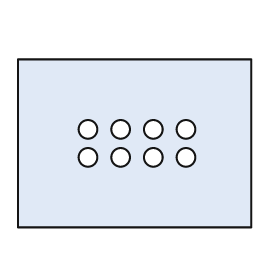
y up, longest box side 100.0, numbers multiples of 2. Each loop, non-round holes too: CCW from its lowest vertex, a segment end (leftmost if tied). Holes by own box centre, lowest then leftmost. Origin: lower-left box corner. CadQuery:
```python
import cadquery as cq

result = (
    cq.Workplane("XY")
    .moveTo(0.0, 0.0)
    .lineTo(100.0, 0.0)
    .lineTo(100.0, 72.0)
    .lineTo(0.0, 72.0)
    .close()
    .moveTo(30.0, 30.0)
    .circle(4.0)
    .moveTo(44.0, 30.0)
    .circle(4.0)
    .moveTo(58.0, 30.0)
    .circle(4.0)
    .moveTo(72.0, 30.0)
    .circle(4.0)
    .moveTo(30.0, 42.0)
    .circle(4.0)
    .moveTo(44.0, 42.0)
    .circle(4.0)
    .moveTo(58.0, 42.0)
    .circle(4.0)
    .moveTo(72.0, 42.0)
    .circle(4.0)
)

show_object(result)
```